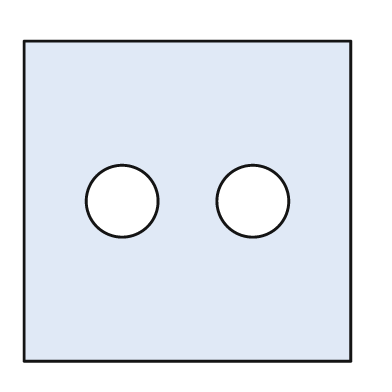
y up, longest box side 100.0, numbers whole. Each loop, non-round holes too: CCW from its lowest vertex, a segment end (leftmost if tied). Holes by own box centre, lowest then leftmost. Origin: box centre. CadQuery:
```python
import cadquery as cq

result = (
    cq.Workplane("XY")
    .moveTo(-50.0, -49.0)
    .lineTo(50.0, -49.0)
    .lineTo(50.0, 49.0)
    .lineTo(-50.0, 49.0)
    .close()
    .moveTo(-20.0, 0.0)
    .circle(11.0)
    .moveTo(20.0, 0.0)
    .circle(11.0)
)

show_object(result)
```